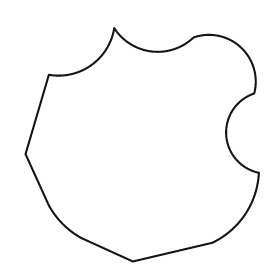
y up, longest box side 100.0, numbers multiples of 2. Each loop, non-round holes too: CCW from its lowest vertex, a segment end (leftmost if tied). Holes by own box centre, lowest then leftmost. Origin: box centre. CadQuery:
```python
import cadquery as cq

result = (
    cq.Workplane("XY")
    .moveTo(-4.0, -50.0)
    .lineTo(30.0, -42.0)
    .threePointArc((44.0, -30.0), (50.0, -12.0))
    .threePointArc((36.0, 4.0), (48.0, 22.0))
    .threePointArc((42.0, 42.0), (22.0, 46.0))
    .threePointArc((4.0, 40.0), (-12.0, 50.0))
    .threePointArc((-22.0, 34.0), (-40.0, 30.0))
    .lineTo(-50.0, -4.0)
    .lineTo(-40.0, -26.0)
    .threePointArc((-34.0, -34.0), (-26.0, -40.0))
    .close()
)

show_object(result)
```